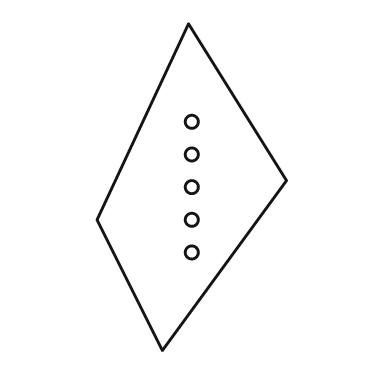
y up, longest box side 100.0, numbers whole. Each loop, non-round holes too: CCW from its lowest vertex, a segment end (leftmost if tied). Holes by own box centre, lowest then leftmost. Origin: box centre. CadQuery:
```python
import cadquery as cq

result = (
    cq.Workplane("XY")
    .moveTo(-9.0, -50.0)
    .lineTo(29.0, 2.0)
    .lineTo(-1.0, 50.0)
    .lineTo(-29.0, -10.0)
    .close()
    .moveTo(0.0, -20.0)
    .circle(2.0)
    .moveTo(0.0, -10.0)
    .circle(2.0)
    .moveTo(0.0, 0.0)
    .circle(2.0)
    .moveTo(0.0, 10.0)
    .circle(2.0)
    .moveTo(0.0, 20.0)
    .circle(2.0)
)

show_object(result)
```